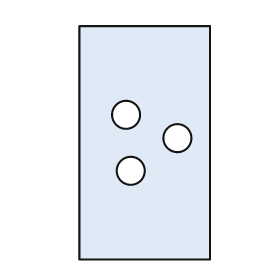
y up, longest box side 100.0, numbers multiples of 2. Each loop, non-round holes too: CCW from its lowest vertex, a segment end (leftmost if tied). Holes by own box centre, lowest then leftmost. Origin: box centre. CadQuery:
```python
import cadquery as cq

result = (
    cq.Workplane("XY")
    .moveTo(-28.0, -50.0)
    .lineTo(28.0, -50.0)
    .lineTo(28.0, 50.0)
    .lineTo(-28.0, 50.0)
    .close()
    .moveTo(-6.0, -12.0)
    .circle(6.0)
    .moveTo(14.0, 2.0)
    .circle(6.0)
    .moveTo(-8.0, 12.0)
    .circle(6.0)
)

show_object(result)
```